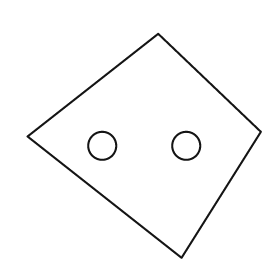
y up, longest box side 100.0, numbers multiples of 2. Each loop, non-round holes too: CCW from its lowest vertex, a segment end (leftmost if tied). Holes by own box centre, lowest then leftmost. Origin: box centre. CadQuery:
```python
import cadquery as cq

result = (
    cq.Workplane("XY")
    .moveTo(16.0, -48.0)
    .lineTo(50.0, 6.0)
    .lineTo(6.0, 48.0)
    .lineTo(-50.0, 4.0)
    .close()
    .moveTo(-18.0, 0.0)
    .circle(6.0)
    .moveTo(18.0, 0.0)
    .circle(6.0)
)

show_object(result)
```